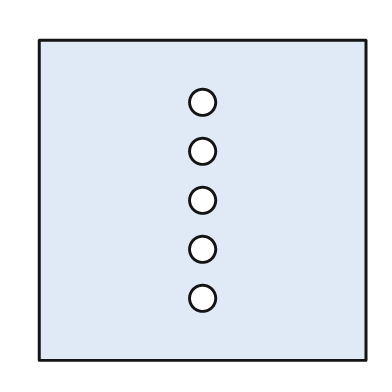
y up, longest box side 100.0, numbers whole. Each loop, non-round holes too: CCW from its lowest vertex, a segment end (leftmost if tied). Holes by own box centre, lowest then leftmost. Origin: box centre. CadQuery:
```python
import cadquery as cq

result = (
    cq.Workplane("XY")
    .moveTo(-50.0, -49.0)
    .lineTo(50.0, -49.0)
    .lineTo(50.0, 49.0)
    .lineTo(-50.0, 49.0)
    .close()
    .moveTo(0.0, -30.0)
    .circle(4.0)
    .moveTo(0.0, -15.0)
    .circle(4.0)
    .moveTo(0.0, 0.0)
    .circle(4.0)
    .moveTo(0.0, 15.0)
    .circle(4.0)
    .moveTo(0.0, 30.0)
    .circle(4.0)
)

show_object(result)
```